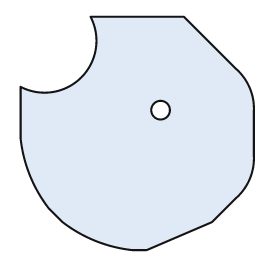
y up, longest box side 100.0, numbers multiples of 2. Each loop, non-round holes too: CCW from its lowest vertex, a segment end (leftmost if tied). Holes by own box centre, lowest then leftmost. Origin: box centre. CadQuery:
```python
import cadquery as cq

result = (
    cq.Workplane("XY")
    .moveTo(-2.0, -50.0)
    .lineTo(4.0, -50.0)
    .lineTo(32.0, -38.0)
    .lineTo(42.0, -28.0)
    .threePointArc((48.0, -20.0), (50.0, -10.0))
    .lineTo(50.0, 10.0)
    .threePointArc((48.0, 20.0), (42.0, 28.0))
    .lineTo(20.0, 50.0)
    .lineTo(-20.0, 50.0)
    .threePointArc((-24.0, 24.0), (-50.0, 20.0))
    .lineTo(-50.0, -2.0)
    .threePointArc((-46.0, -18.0), (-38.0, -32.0))
    .lineTo(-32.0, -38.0)
    .threePointArc((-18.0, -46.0), (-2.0, -50.0))
    .close()
    .moveTo(10.0, 10.0)
    .circle(4.0)
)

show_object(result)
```